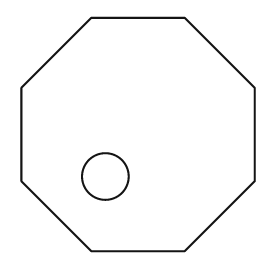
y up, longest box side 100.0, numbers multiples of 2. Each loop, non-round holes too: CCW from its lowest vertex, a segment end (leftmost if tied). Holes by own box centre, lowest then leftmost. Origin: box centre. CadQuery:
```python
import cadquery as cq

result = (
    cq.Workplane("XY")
    .moveTo(-20.0, -50.0)
    .lineTo(20.0, -50.0)
    .lineTo(50.0, -20.0)
    .lineTo(50.0, 20.0)
    .lineTo(20.0, 50.0)
    .lineTo(-20.0, 50.0)
    .lineTo(-50.0, 20.0)
    .lineTo(-50.0, -20.0)
    .close()
    .moveTo(-14.0, -18.0)
    .circle(10.0)
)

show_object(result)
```